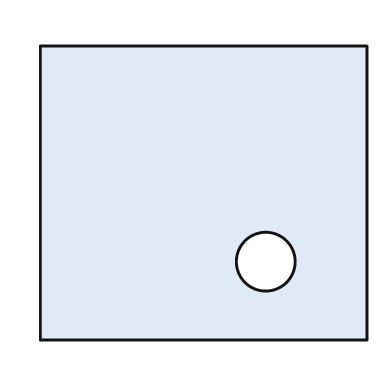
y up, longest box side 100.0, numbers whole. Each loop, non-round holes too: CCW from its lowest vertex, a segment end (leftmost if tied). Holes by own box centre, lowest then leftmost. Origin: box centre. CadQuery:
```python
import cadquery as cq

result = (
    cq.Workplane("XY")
    .moveTo(-50.0, -45.0)
    .lineTo(50.0, -45.0)
    .lineTo(50.0, 45.0)
    .lineTo(-50.0, 45.0)
    .close()
    .moveTo(19.0, -21.0)
    .circle(9.0)
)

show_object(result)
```